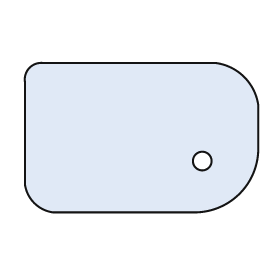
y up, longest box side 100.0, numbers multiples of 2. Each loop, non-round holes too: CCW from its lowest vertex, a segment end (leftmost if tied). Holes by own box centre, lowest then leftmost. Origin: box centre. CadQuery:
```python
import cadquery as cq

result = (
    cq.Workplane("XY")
    .moveTo(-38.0, -32.0)
    .lineTo(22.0, -32.0)
    .threePointArc((42.0, -24.0), (50.0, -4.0))
    .lineTo(50.0, 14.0)
    .threePointArc((44.0, 26.0), (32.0, 32.0))
    .lineTo(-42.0, 32.0)
    .threePointArc((-48.0, 30.0), (-50.0, 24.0))
    .lineTo(-50.0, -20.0)
    .threePointArc((-46.0, -28.0), (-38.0, -32.0))
    .close()
    .moveTo(26.0, -10.0)
    .circle(4.0)
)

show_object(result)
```